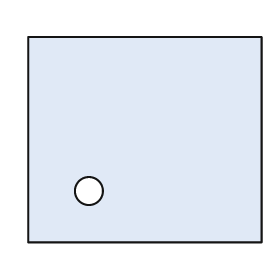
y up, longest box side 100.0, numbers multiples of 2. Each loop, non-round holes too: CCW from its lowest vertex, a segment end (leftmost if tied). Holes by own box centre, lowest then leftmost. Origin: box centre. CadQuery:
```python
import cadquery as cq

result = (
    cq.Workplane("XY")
    .moveTo(-50.0, -44.0)
    .lineTo(50.0, -44.0)
    .lineTo(50.0, 44.0)
    .lineTo(-50.0, 44.0)
    .close()
    .moveTo(-24.0, -22.0)
    .circle(6.0)
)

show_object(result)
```